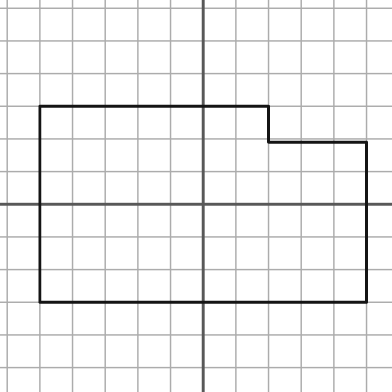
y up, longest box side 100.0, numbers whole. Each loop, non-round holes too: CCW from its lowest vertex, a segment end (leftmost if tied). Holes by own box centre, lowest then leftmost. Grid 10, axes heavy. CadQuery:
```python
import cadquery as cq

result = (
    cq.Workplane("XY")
    .moveTo(-50.0, -30.0)
    .lineTo(50.0, -30.0)
    .lineTo(50.0, 19.0)
    .lineTo(20.0, 19.0)
    .lineTo(20.0, 30.0)
    .lineTo(-50.0, 30.0)
    .close()
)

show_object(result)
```